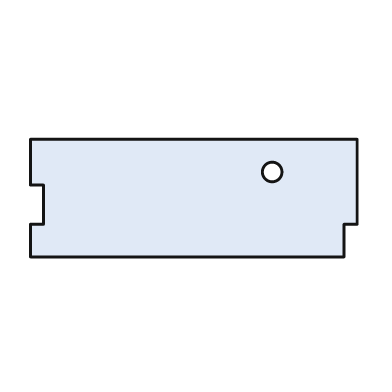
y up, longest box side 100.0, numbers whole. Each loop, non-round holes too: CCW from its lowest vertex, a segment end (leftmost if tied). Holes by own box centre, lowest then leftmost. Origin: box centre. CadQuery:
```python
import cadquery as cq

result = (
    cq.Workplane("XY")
    .moveTo(-50.0, -18.0)
    .lineTo(46.0, -18.0)
    .lineTo(46.0, -8.0)
    .lineTo(50.0, -8.0)
    .lineTo(50.0, 18.0)
    .lineTo(-50.0, 18.0)
    .lineTo(-50.0, 4.0)
    .lineTo(-46.0, 4.0)
    .lineTo(-46.0, -8.0)
    .lineTo(-50.0, -8.0)
    .close()
    .moveTo(24.0, 8.0)
    .circle(3.0)
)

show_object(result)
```